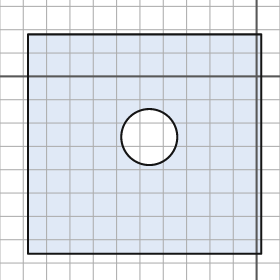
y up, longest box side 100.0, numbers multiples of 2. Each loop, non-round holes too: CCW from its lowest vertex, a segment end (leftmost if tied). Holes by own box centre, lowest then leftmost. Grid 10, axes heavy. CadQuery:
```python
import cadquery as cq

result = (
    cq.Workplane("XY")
    .moveTo(-98.0, -76.0)
    .lineTo(2.0, -76.0)
    .lineTo(2.0, 18.0)
    .lineTo(-98.0, 18.0)
    .close()
    .moveTo(-46.0, -26.0)
    .circle(12.0)
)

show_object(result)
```